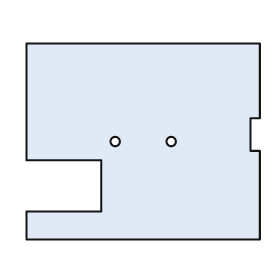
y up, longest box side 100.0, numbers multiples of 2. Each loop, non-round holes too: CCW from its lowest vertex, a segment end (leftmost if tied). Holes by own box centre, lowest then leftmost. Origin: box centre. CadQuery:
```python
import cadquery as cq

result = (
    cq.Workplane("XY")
    .moveTo(-50.0, -42.0)
    .lineTo(50.0, -42.0)
    .lineTo(50.0, -4.0)
    .lineTo(46.0, -4.0)
    .lineTo(46.0, 10.0)
    .lineTo(50.0, 10.0)
    .lineTo(50.0, 42.0)
    .lineTo(-50.0, 42.0)
    .lineTo(-50.0, -8.0)
    .lineTo(-18.0, -8.0)
    .lineTo(-18.0, -30.0)
    .lineTo(-50.0, -30.0)
    .close()
    .moveTo(-12.0, 0.0)
    .circle(2.0)
    .moveTo(12.0, 0.0)
    .circle(2.0)
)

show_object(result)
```